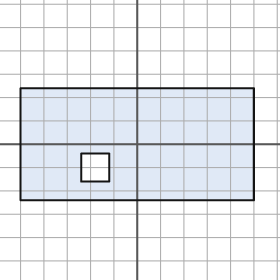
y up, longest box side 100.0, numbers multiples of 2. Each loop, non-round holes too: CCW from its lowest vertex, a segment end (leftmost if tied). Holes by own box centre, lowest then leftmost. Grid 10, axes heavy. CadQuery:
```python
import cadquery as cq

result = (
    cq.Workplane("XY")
    .moveTo(-50.0, -24.0)
    .lineTo(50.0, -24.0)
    .lineTo(50.0, 24.0)
    .lineTo(-50.0, 24.0)
    .close()
    .moveTo(-24.0, -16.0)
    .lineTo(-12.0, -16.0)
    .lineTo(-12.0, -4.0)
    .lineTo(-24.0, -4.0)
    .close()
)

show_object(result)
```